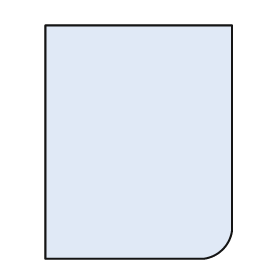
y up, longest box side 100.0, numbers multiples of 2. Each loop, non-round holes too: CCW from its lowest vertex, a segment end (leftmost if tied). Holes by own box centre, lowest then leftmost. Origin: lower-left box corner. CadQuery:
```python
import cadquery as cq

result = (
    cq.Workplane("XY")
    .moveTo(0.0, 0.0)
    .lineTo(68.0, 0.0)
    .threePointArc((76.0, 4.0), (80.0, 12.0))
    .lineTo(80.0, 100.0)
    .lineTo(0.0, 100.0)
    .close()
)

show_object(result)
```